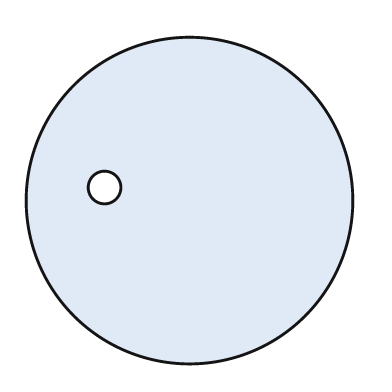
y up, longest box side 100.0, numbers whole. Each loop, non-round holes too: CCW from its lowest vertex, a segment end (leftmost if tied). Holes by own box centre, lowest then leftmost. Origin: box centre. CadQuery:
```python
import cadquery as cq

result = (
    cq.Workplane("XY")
    .moveTo(0.0, 0.0)
    .circle(50.0)
    .moveTo(-26.0, 4.0)
    .circle(5.0)
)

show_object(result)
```